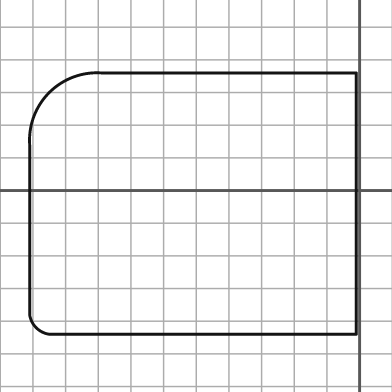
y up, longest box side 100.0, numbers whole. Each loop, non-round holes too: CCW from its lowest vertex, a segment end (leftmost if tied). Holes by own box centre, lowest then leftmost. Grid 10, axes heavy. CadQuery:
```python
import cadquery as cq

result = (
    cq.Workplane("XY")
    .moveTo(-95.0, -44.0)
    .lineTo(-1.0, -44.0)
    .lineTo(-1.0, 36.0)
    .lineTo(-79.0, 36.0)
    .threePointArc((-95.0, 30.0), (-101.0, 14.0))
    .lineTo(-101.0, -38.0)
    .threePointArc((-99.0, -42.0), (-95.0, -44.0))
    .close()
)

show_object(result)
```